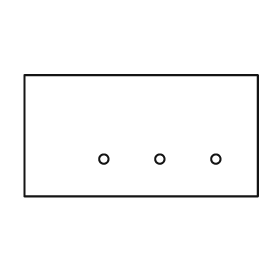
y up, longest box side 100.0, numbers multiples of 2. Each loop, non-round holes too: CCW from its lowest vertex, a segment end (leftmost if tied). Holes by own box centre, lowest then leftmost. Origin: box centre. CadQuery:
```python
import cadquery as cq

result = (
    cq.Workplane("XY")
    .moveTo(-50.0, -26.0)
    .lineTo(50.0, -26.0)
    .lineTo(50.0, 26.0)
    .lineTo(-50.0, 26.0)
    .close()
    .moveTo(-16.0, -10.0)
    .circle(2.0)
    .moveTo(8.0, -10.0)
    .circle(2.0)
    .moveTo(32.0, -10.0)
    .circle(2.0)
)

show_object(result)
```